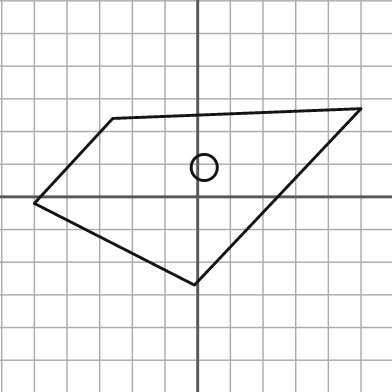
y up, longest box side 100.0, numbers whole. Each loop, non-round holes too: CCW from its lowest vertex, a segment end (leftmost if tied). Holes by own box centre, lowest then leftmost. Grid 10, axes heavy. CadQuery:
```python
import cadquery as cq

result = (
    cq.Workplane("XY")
    .moveTo(-1.0, -27.0)
    .lineTo(50.0, 27.0)
    .lineTo(-26.0, 24.0)
    .lineTo(-50.0, -2.0)
    .close()
    .moveTo(2.0, 9.0)
    .circle(4.0)
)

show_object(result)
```